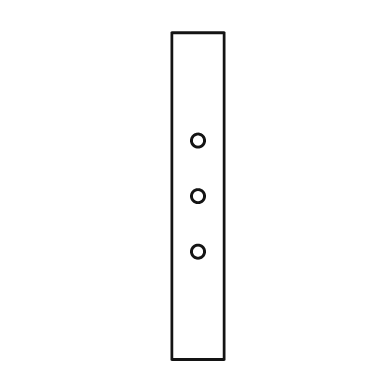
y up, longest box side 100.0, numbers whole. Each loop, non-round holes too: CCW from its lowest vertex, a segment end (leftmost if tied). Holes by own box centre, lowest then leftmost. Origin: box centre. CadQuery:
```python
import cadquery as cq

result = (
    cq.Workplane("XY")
    .moveTo(-8.0, -50.0)
    .lineTo(8.0, -50.0)
    .lineTo(8.0, 50.0)
    .lineTo(-8.0, 50.0)
    .close()
    .moveTo(0.0, -17.0)
    .circle(2.0)
    .moveTo(0.0, 0.0)
    .circle(2.0)
    .moveTo(0.0, 17.0)
    .circle(2.0)
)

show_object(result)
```